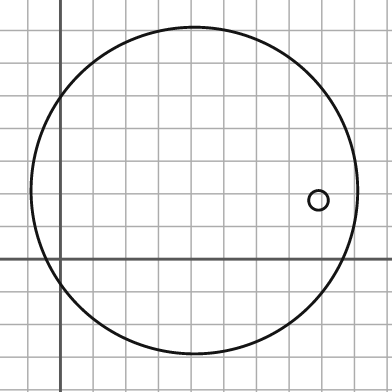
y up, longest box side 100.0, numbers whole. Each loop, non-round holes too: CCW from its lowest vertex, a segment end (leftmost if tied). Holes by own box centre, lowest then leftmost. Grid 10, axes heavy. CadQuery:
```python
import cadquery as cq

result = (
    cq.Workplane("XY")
    .moveTo(41.0, 21.0)
    .circle(50.0)
    .moveTo(79.0, 18.0)
    .circle(3.0)
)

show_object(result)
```